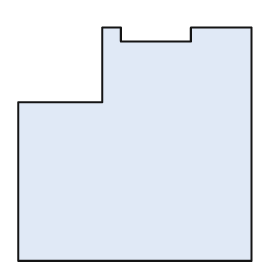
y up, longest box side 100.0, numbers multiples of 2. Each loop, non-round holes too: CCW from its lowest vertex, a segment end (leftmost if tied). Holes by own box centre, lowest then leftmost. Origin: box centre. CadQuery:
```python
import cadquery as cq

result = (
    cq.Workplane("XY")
    .moveTo(-50.0, -50.0)
    .lineTo(50.0, -50.0)
    .lineTo(50.0, 50.0)
    .lineTo(24.0, 50.0)
    .lineTo(24.0, 44.0)
    .lineTo(-6.0, 44.0)
    .lineTo(-6.0, 50.0)
    .lineTo(-14.0, 50.0)
    .lineTo(-14.0, 18.0)
    .lineTo(-50.0, 18.0)
    .close()
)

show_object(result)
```